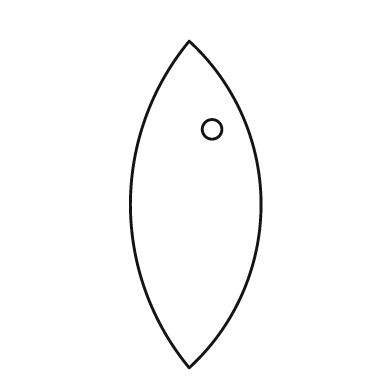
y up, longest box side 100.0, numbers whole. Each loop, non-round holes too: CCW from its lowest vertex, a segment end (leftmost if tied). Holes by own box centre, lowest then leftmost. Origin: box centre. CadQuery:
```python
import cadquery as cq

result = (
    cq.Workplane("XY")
    .moveTo(-2.0, -50.0)
    .threePointArc((20.0, 0.0), (-2.0, 50.0))
    .threePointArc((-20.0, 0.0), (-2.0, -50.0))
    .close()
    .moveTo(5.0, 23.0)
    .circle(3.0)
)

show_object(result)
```